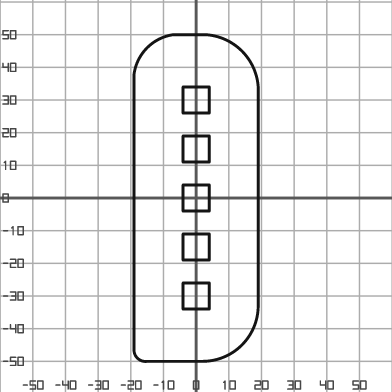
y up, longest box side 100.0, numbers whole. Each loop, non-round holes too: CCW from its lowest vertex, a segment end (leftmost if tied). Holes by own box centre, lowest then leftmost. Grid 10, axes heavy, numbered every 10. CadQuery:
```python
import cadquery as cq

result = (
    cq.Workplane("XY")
    .moveTo(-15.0, -50.0)
    .lineTo(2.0, -50.0)
    .threePointArc((14.0, -45.0), (19.0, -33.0))
    .lineTo(19.0, 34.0)
    .threePointArc((14.0, 45.0), (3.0, 50.0))
    .lineTo(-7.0, 50.0)
    .threePointArc((-15.0, 46.0), (-19.0, 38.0))
    .lineTo(-19.0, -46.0)
    .threePointArc((-18.0, -49.0), (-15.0, -50.0))
    .close()
    .moveTo(-4.0, -34.0)
    .lineTo(4.0, -34.0)
    .lineTo(4.0, -26.0)
    .lineTo(-4.0, -26.0)
    .close()
    .moveTo(-4.0, -19.0)
    .lineTo(4.0, -19.0)
    .lineTo(4.0, -11.0)
    .lineTo(-4.0, -11.0)
    .close()
    .moveTo(-4.0, -4.0)
    .lineTo(4.0, -4.0)
    .lineTo(4.0, 4.0)
    .lineTo(-4.0, 4.0)
    .close()
    .moveTo(-4.0, 11.0)
    .lineTo(4.0, 11.0)
    .lineTo(4.0, 19.0)
    .lineTo(-4.0, 19.0)
    .close()
    .moveTo(-4.0, 26.0)
    .lineTo(4.0, 26.0)
    .lineTo(4.0, 34.0)
    .lineTo(-4.0, 34.0)
    .close()
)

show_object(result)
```